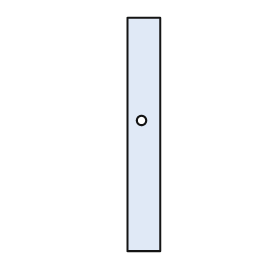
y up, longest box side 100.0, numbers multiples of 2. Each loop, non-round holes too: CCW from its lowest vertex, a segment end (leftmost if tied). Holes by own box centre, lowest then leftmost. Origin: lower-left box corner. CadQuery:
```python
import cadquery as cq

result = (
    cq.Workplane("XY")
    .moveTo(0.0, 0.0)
    .lineTo(14.0, 0.0)
    .lineTo(14.0, 100.0)
    .lineTo(0.0, 100.0)
    .close()
    .moveTo(6.0, 56.0)
    .circle(2.0)
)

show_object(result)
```